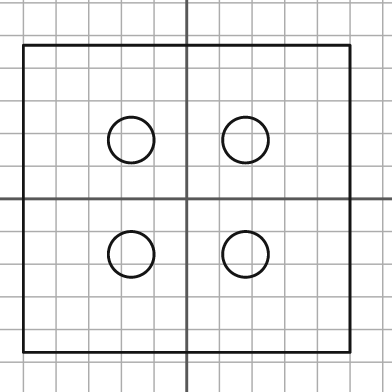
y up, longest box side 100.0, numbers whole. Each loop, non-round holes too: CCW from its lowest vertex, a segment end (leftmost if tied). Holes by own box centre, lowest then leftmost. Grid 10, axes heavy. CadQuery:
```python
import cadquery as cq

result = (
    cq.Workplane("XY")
    .moveTo(-50.0, -47.0)
    .lineTo(50.0, -47.0)
    .lineTo(50.0, 47.0)
    .lineTo(-50.0, 47.0)
    .close()
    .moveTo(-17.0, -17.0)
    .circle(7.0)
    .moveTo(18.0, -17.0)
    .circle(7.0)
    .moveTo(-17.0, 18.0)
    .circle(7.0)
    .moveTo(18.0, 18.0)
    .circle(7.0)
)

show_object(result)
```